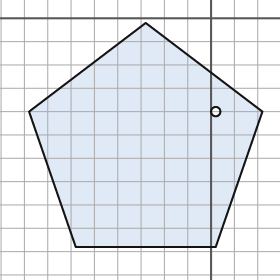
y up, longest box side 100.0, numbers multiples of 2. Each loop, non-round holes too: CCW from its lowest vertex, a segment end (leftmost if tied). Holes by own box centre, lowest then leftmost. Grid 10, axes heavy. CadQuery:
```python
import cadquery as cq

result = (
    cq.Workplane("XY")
    .moveTo(-58.0, -98.0)
    .lineTo(2.0, -98.0)
    .lineTo(22.0, -40.0)
    .lineTo(-28.0, -2.0)
    .lineTo(-78.0, -40.0)
    .close()
    .moveTo(2.0, -40.0)
    .circle(2.0)
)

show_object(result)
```